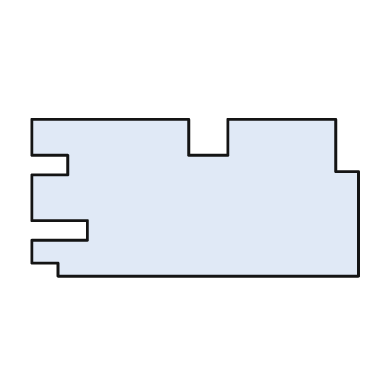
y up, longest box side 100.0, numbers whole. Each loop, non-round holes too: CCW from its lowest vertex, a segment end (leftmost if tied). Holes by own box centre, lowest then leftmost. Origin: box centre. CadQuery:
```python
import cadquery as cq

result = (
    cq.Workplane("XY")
    .moveTo(-42.0, -24.0)
    .lineTo(50.0, -24.0)
    .lineTo(50.0, 8.0)
    .lineTo(43.0, 8.0)
    .lineTo(43.0, 24.0)
    .lineTo(10.0, 24.0)
    .lineTo(10.0, 13.0)
    .lineTo(-2.0, 13.0)
    .lineTo(-2.0, 24.0)
    .lineTo(-50.0, 24.0)
    .lineTo(-50.0, 13.0)
    .lineTo(-39.0, 13.0)
    .lineTo(-39.0, 7.0)
    .lineTo(-50.0, 7.0)
    .lineTo(-50.0, -7.0)
    .lineTo(-33.0, -7.0)
    .lineTo(-33.0, -13.0)
    .lineTo(-50.0, -13.0)
    .lineTo(-50.0, -20.0)
    .lineTo(-42.0, -20.0)
    .close()
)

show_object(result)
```